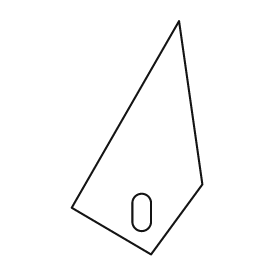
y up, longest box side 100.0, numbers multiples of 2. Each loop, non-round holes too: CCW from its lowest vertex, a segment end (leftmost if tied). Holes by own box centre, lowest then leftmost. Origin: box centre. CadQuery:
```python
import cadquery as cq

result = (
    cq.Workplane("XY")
    .moveTo(6.0, -50.0)
    .lineTo(28.0, -20.0)
    .lineTo(18.0, 50.0)
    .lineTo(-28.0, -30.0)
    .close()
    .moveTo(-2.0, -36.0)
    .threePointArc((2.0, -40.0), (6.0, -36.0))
    .lineTo(6.0, -28.0)
    .threePointArc((2.0, -24.0), (-2.0, -28.0))
    .close()
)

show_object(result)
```